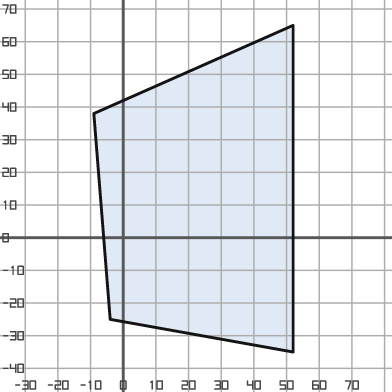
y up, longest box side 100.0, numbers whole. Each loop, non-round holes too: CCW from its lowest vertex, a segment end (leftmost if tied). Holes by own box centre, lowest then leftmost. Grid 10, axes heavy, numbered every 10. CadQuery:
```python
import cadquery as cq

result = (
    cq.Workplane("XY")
    .moveTo(52.0, -35.0)
    .lineTo(52.0, 65.0)
    .lineTo(-9.0, 38.0)
    .lineTo(-4.0, -25.0)
    .close()
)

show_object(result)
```